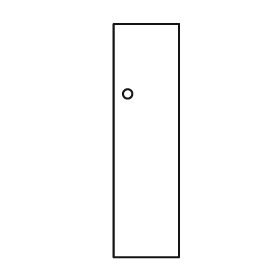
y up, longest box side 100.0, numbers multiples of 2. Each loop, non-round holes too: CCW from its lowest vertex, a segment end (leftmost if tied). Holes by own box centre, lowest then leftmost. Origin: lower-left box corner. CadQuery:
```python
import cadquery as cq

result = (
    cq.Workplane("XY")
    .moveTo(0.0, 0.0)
    .lineTo(28.0, 0.0)
    .lineTo(28.0, 100.0)
    .lineTo(0.0, 100.0)
    .close()
    .moveTo(6.0, 70.0)
    .circle(2.0)
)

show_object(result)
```